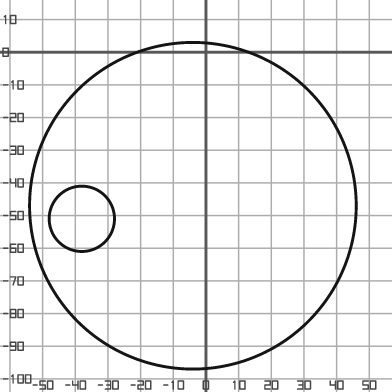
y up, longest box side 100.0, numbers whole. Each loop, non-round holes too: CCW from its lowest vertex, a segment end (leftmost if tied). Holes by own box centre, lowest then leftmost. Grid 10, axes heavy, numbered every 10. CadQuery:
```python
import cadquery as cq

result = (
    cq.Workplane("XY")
    .moveTo(-4.0, -47.0)
    .circle(50.0)
    .moveTo(-38.0, -51.0)
    .circle(10.0)
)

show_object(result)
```